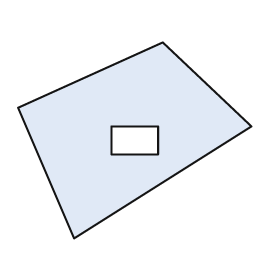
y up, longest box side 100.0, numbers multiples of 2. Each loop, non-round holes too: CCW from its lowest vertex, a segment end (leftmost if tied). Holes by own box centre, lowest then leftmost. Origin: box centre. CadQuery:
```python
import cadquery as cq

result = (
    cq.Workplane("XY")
    .moveTo(-26.0, -42.0)
    .lineTo(50.0, 6.0)
    .lineTo(12.0, 42.0)
    .lineTo(-50.0, 14.0)
    .close()
    .moveTo(-10.0, -6.0)
    .lineTo(10.0, -6.0)
    .lineTo(10.0, 6.0)
    .lineTo(-10.0, 6.0)
    .close()
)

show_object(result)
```